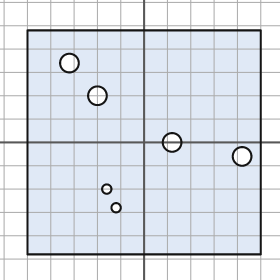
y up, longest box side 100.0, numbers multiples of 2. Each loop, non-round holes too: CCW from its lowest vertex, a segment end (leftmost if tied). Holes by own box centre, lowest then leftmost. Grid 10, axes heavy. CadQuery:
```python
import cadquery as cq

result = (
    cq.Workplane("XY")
    .moveTo(-50.0, -48.0)
    .lineTo(50.0, -48.0)
    .lineTo(50.0, 48.0)
    .lineTo(-50.0, 48.0)
    .close()
    .moveTo(-12.0, -28.0)
    .circle(2.0)
    .moveTo(-16.0, -20.0)
    .circle(2.0)
    .moveTo(42.0, -6.0)
    .circle(4.0)
    .moveTo(12.0, 0.0)
    .circle(4.0)
    .moveTo(-20.0, 20.0)
    .circle(4.0)
    .moveTo(-32.0, 34.0)
    .circle(4.0)
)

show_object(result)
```